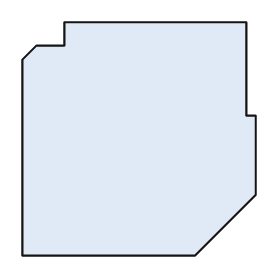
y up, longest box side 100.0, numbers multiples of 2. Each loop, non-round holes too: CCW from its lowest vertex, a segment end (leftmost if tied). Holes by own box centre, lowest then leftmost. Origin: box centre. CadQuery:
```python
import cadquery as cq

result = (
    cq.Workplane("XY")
    .moveTo(-50.0, -50.0)
    .lineTo(24.0, -50.0)
    .lineTo(50.0, -24.0)
    .lineTo(50.0, 10.0)
    .lineTo(46.0, 10.0)
    .lineTo(46.0, 50.0)
    .lineTo(-32.0, 50.0)
    .lineTo(-32.0, 40.0)
    .lineTo(-44.0, 40.0)
    .lineTo(-50.0, 34.0)
    .close()
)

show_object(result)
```